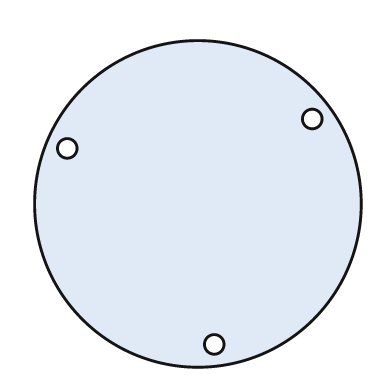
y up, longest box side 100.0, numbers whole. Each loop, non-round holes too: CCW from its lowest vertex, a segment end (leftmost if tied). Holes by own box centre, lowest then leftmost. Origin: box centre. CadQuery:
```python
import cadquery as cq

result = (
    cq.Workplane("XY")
    .moveTo(0.0, 0.0)
    .circle(50.0)
    .moveTo(5.0, -43.0)
    .circle(3.0)
    .moveTo(-40.0, 17.0)
    .circle(3.0)
    .moveTo(35.0, 26.0)
    .circle(3.0)
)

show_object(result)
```